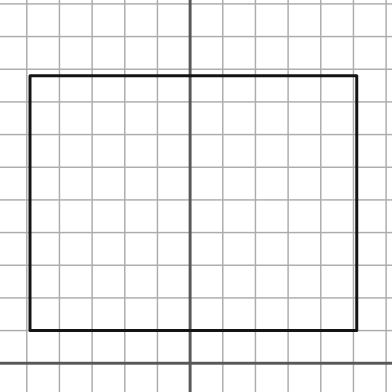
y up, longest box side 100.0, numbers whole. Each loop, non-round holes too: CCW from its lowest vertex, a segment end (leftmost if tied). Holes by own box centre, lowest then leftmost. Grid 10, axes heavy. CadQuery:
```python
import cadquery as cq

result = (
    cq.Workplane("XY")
    .moveTo(-49.0, 10.0)
    .lineTo(51.0, 10.0)
    .lineTo(51.0, 88.0)
    .lineTo(-49.0, 88.0)
    .close()
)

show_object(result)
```